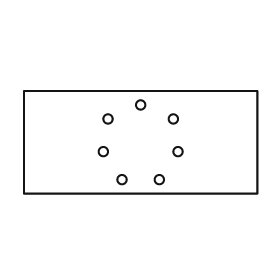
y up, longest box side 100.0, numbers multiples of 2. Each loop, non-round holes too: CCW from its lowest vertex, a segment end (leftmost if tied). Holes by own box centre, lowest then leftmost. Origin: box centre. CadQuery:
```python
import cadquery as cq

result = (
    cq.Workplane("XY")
    .moveTo(-50.0, -22.0)
    .lineTo(50.0, -22.0)
    .lineTo(50.0, 22.0)
    .lineTo(-50.0, 22.0)
    .close()
    .moveTo(-8.0, -16.0)
    .circle(2.0)
    .moveTo(8.0, -16.0)
    .circle(2.0)
    .moveTo(-16.0, -4.0)
    .circle(2.0)
    .moveTo(16.0, -4.0)
    .circle(2.0)
    .moveTo(-14.0, 10.0)
    .circle(2.0)
    .moveTo(14.0, 10.0)
    .circle(2.0)
    .moveTo(0.0, 16.0)
    .circle(2.0)
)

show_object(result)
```